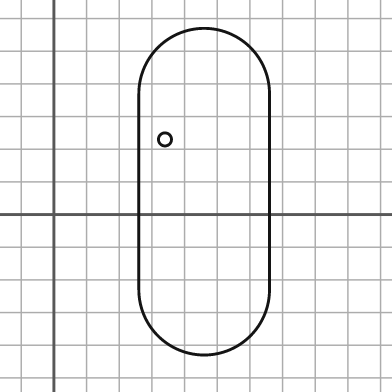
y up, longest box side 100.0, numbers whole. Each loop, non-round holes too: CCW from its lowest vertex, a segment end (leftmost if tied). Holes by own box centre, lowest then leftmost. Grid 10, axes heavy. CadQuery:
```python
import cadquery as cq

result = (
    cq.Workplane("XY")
    .moveTo(26.0, -23.0)
    .threePointArc((46.0, -43.0), (66.0, -23.0))
    .lineTo(66.0, 37.0)
    .threePointArc((46.0, 57.0), (26.0, 37.0))
    .close()
    .moveTo(34.0, 23.0)
    .circle(2.0)
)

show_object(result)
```